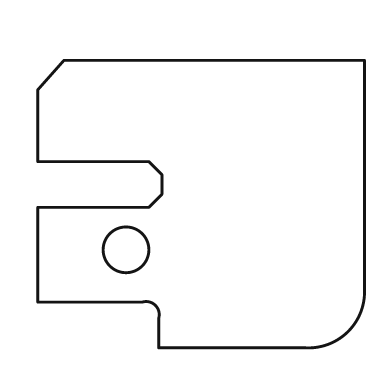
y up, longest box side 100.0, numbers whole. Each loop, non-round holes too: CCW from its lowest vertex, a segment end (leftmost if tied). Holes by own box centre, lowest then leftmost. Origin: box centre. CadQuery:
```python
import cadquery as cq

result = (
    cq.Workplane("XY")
    .moveTo(-13.0, -44.0)
    .lineTo(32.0, -44.0)
    .threePointArc((45.0, -39.0), (50.0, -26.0))
    .lineTo(50.0, 44.0)
    .lineTo(-42.0, 44.0)
    .lineTo(-50.0, 35.0)
    .lineTo(-50.0, 13.0)
    .lineTo(-16.0, 13.0)
    .lineTo(-12.0, 9.0)
    .lineTo(-12.0, 3.0)
    .lineTo(-16.0, -1.0)
    .lineTo(-50.0, -1.0)
    .lineTo(-50.0, -30.0)
    .lineTo(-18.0, -30.0)
    .threePointArc((-14.0, -31.0), (-13.0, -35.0))
    .close()
    .moveTo(-23.0, -14.0)
    .circle(7.0)
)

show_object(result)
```